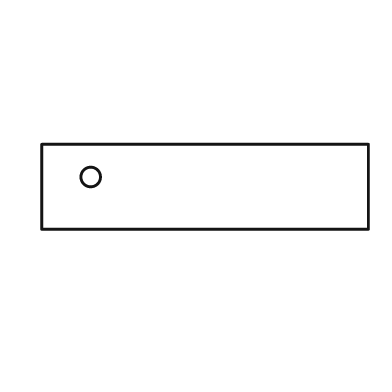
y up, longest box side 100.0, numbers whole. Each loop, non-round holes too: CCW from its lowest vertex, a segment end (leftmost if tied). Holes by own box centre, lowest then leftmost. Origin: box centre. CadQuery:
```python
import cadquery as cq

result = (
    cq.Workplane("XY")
    .moveTo(-50.0, -13.0)
    .lineTo(50.0, -13.0)
    .lineTo(50.0, 13.0)
    .lineTo(-50.0, 13.0)
    .close()
    .moveTo(-35.0, 3.0)
    .circle(3.0)
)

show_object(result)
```